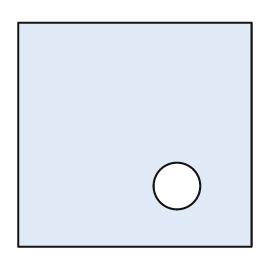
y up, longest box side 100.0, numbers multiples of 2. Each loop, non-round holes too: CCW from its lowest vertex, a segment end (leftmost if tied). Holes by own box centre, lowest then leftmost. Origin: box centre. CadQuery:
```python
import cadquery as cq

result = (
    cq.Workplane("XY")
    .moveTo(-50.0, -48.0)
    .lineTo(50.0, -48.0)
    .lineTo(50.0, 48.0)
    .lineTo(-50.0, 48.0)
    .close()
    .moveTo(18.0, -22.0)
    .circle(10.0)
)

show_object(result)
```